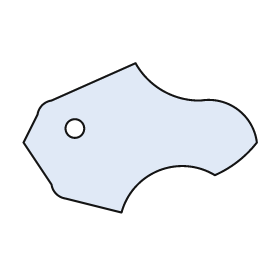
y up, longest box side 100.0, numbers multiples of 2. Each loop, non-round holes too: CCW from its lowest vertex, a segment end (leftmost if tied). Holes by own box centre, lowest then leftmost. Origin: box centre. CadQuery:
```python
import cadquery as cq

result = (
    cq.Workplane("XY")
    .moveTo(-8.0, -32.0)
    .threePointArc((8.0, -14.0), (32.0, -16.0))
    .threePointArc((42.0, -10.0), (50.0, -2.0))
    .threePointArc((42.0, 12.0), (26.0, 16.0))
    .threePointArc((10.0, 20.0), (-2.0, 32.0))
    .lineTo(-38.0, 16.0)
    .threePointArc((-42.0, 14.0), (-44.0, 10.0))
    .lineTo(-50.0, -2.0)
    .lineTo(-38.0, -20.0)
    .threePointArc((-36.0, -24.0), (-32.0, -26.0))
    .close()
    .moveTo(-28.0, 4.0)
    .circle(4.0)
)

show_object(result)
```